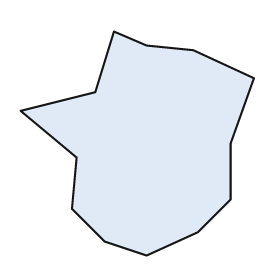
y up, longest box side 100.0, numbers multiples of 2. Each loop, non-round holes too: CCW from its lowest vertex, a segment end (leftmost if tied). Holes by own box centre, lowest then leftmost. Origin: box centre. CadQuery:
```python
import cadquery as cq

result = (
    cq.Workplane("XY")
    .moveTo(4.0, -48.0)
    .lineTo(26.0, -38.0)
    .lineTo(40.0, -24.0)
    .lineTo(40.0, 0.0)
    .lineTo(50.0, 28.0)
    .lineTo(24.0, 40.0)
    .lineTo(4.0, 42.0)
    .lineTo(-10.0, 48.0)
    .lineTo(-18.0, 22.0)
    .lineTo(-50.0, 14.0)
    .lineTo(-26.0, -6.0)
    .lineTo(-28.0, -28.0)
    .lineTo(-14.0, -42.0)
    .close()
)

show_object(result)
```